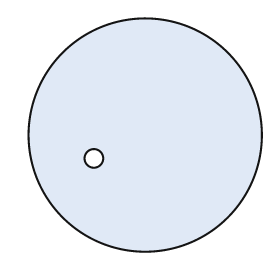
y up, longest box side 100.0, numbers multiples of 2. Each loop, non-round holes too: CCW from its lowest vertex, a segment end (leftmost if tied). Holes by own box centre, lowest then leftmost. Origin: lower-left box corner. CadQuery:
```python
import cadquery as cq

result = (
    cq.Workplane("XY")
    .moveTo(50.0, 50.0)
    .circle(50.0)
    .moveTo(28.0, 40.0)
    .circle(4.0)
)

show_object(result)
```